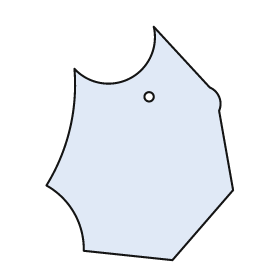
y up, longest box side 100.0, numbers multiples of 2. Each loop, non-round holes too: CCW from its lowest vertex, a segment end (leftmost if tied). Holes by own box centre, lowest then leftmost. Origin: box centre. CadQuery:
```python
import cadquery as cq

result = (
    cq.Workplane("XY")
    .moveTo(14.0, -50.0)
    .lineTo(40.0, -20.0)
    .lineTo(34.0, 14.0)
    .threePointArc((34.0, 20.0), (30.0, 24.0))
    .lineTo(6.0, 50.0)
    .threePointArc((-4.0, 28.0), (-28.0, 32.0))
    .threePointArc((-30.0, 6.0), (-40.0, -18.0))
    .threePointArc((-28.0, -30.0), (-24.0, -46.0))
    .close()
    .moveTo(4.0, 20.0)
    .circle(2.0)
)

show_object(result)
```